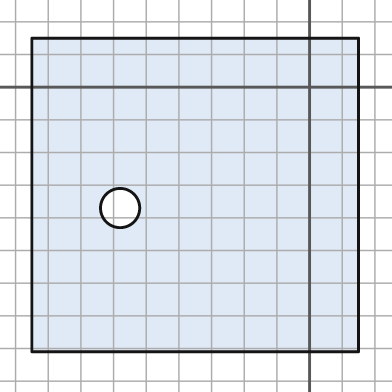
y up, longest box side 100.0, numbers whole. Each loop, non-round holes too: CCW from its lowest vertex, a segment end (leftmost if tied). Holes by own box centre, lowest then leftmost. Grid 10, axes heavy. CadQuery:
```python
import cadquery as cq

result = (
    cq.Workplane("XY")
    .moveTo(-85.0, -81.0)
    .lineTo(15.0, -81.0)
    .lineTo(15.0, 15.0)
    .lineTo(-85.0, 15.0)
    .close()
    .moveTo(-58.0, -37.0)
    .circle(6.0)
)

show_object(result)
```